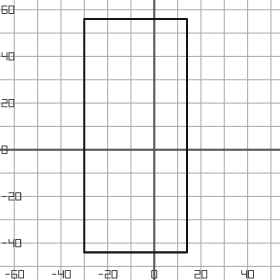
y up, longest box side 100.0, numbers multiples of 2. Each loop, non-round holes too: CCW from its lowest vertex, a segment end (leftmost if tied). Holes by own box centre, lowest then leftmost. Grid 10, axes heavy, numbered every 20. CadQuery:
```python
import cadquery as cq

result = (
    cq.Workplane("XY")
    .moveTo(-30.0, -44.0)
    .lineTo(14.0, -44.0)
    .lineTo(14.0, 56.0)
    .lineTo(-30.0, 56.0)
    .close()
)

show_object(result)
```